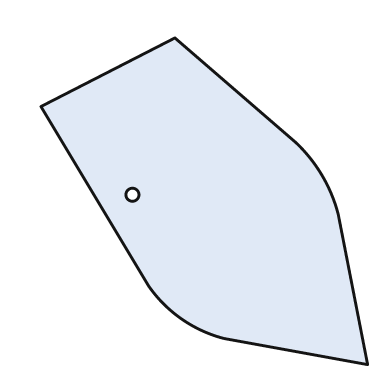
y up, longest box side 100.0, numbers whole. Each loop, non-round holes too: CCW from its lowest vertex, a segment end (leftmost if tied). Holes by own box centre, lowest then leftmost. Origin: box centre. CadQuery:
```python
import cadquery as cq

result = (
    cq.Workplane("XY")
    .moveTo(50.0, -50.0)
    .lineTo(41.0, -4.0)
    .threePointArc((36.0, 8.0), (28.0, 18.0))
    .lineTo(-9.0, 50.0)
    .lineTo(-50.0, 29.0)
    .lineTo(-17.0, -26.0)
    .threePointArc((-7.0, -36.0), (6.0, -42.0))
    .close()
    .moveTo(-22.0, 2.0)
    .circle(2.0)
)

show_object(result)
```